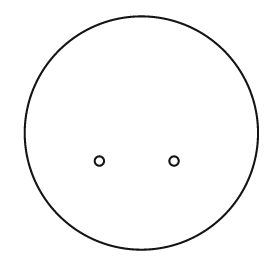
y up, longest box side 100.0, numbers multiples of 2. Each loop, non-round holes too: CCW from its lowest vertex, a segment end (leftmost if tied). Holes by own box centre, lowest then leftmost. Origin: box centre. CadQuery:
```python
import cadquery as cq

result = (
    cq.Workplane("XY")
    .moveTo(0.0, 0.0)
    .circle(50.0)
    .moveTo(-18.0, -12.0)
    .circle(2.0)
    .moveTo(14.0, -12.0)
    .circle(2.0)
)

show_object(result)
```